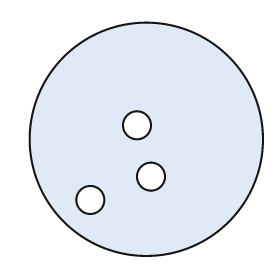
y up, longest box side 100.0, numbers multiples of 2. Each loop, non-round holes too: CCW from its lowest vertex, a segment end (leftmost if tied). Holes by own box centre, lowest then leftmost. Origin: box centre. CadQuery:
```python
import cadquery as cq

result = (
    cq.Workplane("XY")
    .moveTo(0.0, 0.0)
    .circle(50.0)
    .moveTo(-24.0, -26.0)
    .circle(6.0)
    .moveTo(2.0, -16.0)
    .circle(6.0)
    .moveTo(-4.0, 6.0)
    .circle(6.0)
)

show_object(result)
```